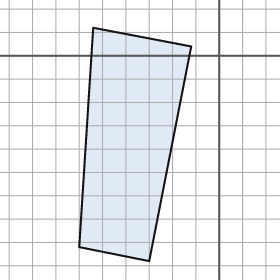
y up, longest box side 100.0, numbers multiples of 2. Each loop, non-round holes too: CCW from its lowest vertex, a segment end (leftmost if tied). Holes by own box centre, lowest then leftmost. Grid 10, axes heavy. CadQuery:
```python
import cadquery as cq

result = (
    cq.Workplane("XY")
    .moveTo(-30.0, -88.0)
    .lineTo(-12.0, 4.0)
    .lineTo(-54.0, 12.0)
    .lineTo(-60.0, -82.0)
    .close()
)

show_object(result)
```